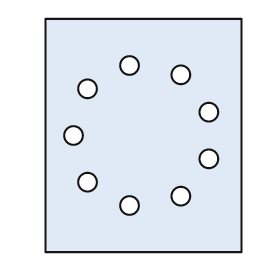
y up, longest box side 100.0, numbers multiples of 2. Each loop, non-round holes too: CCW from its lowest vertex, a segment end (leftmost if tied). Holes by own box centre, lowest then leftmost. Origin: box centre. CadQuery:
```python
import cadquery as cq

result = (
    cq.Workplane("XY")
    .moveTo(-42.0, -50.0)
    .lineTo(42.0, -50.0)
    .lineTo(42.0, 50.0)
    .lineTo(-42.0, 50.0)
    .close()
    .moveTo(-6.0, -30.0)
    .circle(4.0)
    .moveTo(16.0, -26.0)
    .circle(4.0)
    .moveTo(-24.0, -20.0)
    .circle(4.0)
    .moveTo(28.0, -10.0)
    .circle(4.0)
    .moveTo(-30.0, 0.0)
    .circle(4.0)
    .moveTo(28.0, 10.0)
    .circle(4.0)
    .moveTo(-24.0, 20.0)
    .circle(4.0)
    .moveTo(16.0, 26.0)
    .circle(4.0)
    .moveTo(-6.0, 30.0)
    .circle(4.0)
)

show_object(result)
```